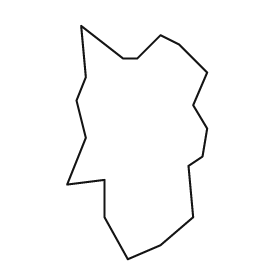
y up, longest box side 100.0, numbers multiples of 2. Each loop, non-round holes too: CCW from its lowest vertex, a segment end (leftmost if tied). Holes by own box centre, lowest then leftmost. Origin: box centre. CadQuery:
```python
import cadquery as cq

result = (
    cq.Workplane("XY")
    .moveTo(-4.0, -50.0)
    .lineTo(10.0, -44.0)
    .lineTo(24.0, -32.0)
    .lineTo(22.0, -10.0)
    .lineTo(28.0, -6.0)
    .lineTo(30.0, 6.0)
    .lineTo(24.0, 16.0)
    .lineTo(30.0, 30.0)
    .lineTo(18.0, 42.0)
    .lineTo(10.0, 46.0)
    .lineTo(0.0, 36.0)
    .lineTo(-6.0, 36.0)
    .lineTo(-24.0, 50.0)
    .lineTo(-22.0, 28.0)
    .lineTo(-26.0, 18.0)
    .lineTo(-22.0, 2.0)
    .lineTo(-30.0, -18.0)
    .lineTo(-14.0, -16.0)
    .lineTo(-14.0, -32.0)
    .close()
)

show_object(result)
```